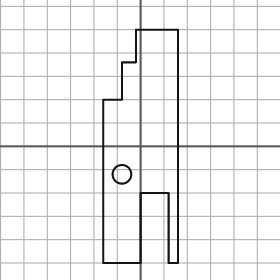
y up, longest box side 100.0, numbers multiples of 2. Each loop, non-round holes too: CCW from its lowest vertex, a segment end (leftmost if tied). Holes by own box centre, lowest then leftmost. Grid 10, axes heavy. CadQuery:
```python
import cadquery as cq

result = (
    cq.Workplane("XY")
    .moveTo(-16.0, -50.0)
    .lineTo(0.0, -50.0)
    .lineTo(0.0, -20.0)
    .lineTo(12.0, -20.0)
    .lineTo(12.0, -50.0)
    .lineTo(16.0, -50.0)
    .lineTo(16.0, 50.0)
    .lineTo(-2.0, 50.0)
    .lineTo(-2.0, 36.0)
    .lineTo(-8.0, 36.0)
    .lineTo(-8.0, 20.0)
    .lineTo(-16.0, 20.0)
    .close()
    .moveTo(-8.0, -12.0)
    .circle(4.0)
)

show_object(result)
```